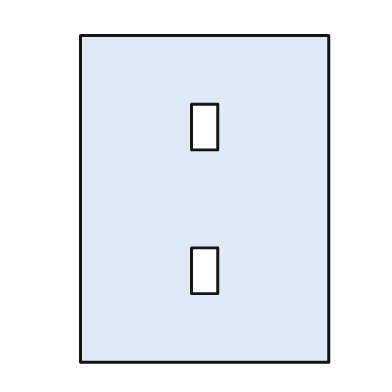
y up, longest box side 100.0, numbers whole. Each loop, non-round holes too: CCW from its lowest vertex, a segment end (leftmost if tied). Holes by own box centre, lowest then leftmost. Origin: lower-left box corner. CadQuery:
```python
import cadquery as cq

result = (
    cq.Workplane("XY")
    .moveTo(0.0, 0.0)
    .lineTo(76.0, 0.0)
    .lineTo(76.0, 100.0)
    .lineTo(0.0, 100.0)
    .close()
    .moveTo(34.0, 21.0)
    .lineTo(42.0, 21.0)
    .lineTo(42.0, 35.0)
    .lineTo(34.0, 35.0)
    .close()
    .moveTo(34.0, 65.0)
    .lineTo(42.0, 65.0)
    .lineTo(42.0, 79.0)
    .lineTo(34.0, 79.0)
    .close()
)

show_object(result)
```